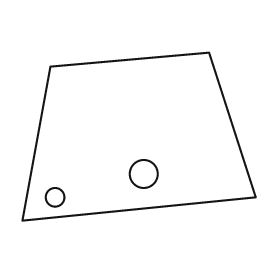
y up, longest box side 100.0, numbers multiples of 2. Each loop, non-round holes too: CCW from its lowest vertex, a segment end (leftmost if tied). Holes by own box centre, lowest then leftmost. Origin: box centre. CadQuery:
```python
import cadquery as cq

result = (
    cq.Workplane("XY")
    .moveTo(-50.0, -36.0)
    .lineTo(50.0, -26.0)
    .lineTo(30.0, 36.0)
    .lineTo(-38.0, 30.0)
    .close()
    .moveTo(-36.0, -26.0)
    .circle(4.0)
    .moveTo(2.0, -16.0)
    .circle(6.0)
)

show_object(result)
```